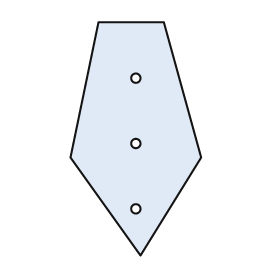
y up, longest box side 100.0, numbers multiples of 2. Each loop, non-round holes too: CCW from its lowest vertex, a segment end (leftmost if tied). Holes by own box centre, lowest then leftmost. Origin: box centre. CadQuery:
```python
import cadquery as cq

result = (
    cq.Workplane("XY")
    .moveTo(2.0, -50.0)
    .lineTo(28.0, -8.0)
    .lineTo(12.0, 50.0)
    .lineTo(-16.0, 50.0)
    .lineTo(-28.0, -8.0)
    .close()
    .moveTo(0.0, -30.0)
    .circle(2.0)
    .moveTo(0.0, -2.0)
    .circle(2.0)
    .moveTo(0.0, 26.0)
    .circle(2.0)
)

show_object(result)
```